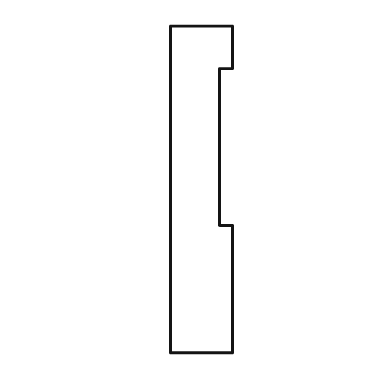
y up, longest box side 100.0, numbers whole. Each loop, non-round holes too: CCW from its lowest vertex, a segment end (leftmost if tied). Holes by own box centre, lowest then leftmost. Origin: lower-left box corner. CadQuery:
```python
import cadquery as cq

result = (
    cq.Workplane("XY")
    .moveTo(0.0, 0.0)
    .lineTo(19.0, 0.0)
    .lineTo(19.0, 39.0)
    .lineTo(15.0, 39.0)
    .lineTo(15.0, 87.0)
    .lineTo(19.0, 87.0)
    .lineTo(19.0, 100.0)
    .lineTo(0.0, 100.0)
    .close()
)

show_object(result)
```